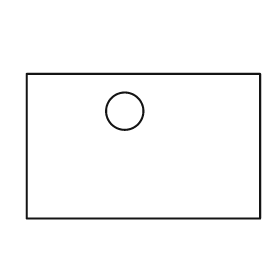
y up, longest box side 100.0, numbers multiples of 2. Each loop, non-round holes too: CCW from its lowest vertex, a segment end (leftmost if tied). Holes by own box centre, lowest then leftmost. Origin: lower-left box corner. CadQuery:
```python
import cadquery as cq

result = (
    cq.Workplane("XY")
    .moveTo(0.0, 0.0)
    .lineTo(100.0, 0.0)
    .lineTo(100.0, 62.0)
    .lineTo(0.0, 62.0)
    .close()
    .moveTo(42.0, 46.0)
    .circle(8.0)
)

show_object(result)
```